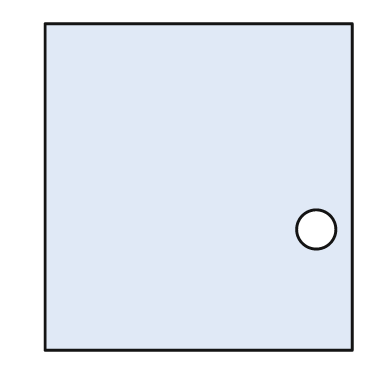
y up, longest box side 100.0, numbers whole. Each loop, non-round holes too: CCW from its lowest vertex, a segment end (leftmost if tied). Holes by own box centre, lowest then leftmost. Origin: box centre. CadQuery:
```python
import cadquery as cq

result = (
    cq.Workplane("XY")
    .moveTo(-47.0, -50.0)
    .lineTo(47.0, -50.0)
    .lineTo(47.0, 50.0)
    .lineTo(-47.0, 50.0)
    .close()
    .moveTo(36.0, -13.0)
    .circle(6.0)
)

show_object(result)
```